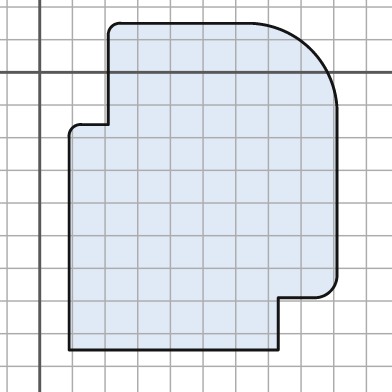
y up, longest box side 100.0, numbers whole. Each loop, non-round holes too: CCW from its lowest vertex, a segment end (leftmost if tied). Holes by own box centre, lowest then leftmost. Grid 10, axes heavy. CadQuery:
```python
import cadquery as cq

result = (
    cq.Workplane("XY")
    .moveTo(9.0, -85.0)
    .lineTo(73.0, -85.0)
    .lineTo(73.0, -69.0)
    .lineTo(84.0, -69.0)
    .threePointArc((89.0, -67.0), (91.0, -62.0))
    .lineTo(91.0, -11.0)
    .threePointArc((83.0, 7.0), (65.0, 15.0))
    .lineTo(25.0, 15.0)
    .threePointArc((22.0, 14.0), (21.0, 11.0))
    .lineTo(21.0, -16.0)
    .lineTo(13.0, -16.0)
    .threePointArc((10.0, -17.0), (9.0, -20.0))
    .close()
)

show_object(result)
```